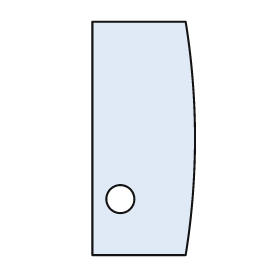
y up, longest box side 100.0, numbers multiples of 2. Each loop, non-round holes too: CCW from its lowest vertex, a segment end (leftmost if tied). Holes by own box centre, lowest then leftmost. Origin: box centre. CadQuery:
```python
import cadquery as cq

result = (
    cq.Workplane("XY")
    .moveTo(-22.0, -50.0)
    .lineTo(18.0, -50.0)
    .threePointArc((22.0, 0.0), (18.0, 50.0))
    .lineTo(-22.0, 50.0)
    .close()
    .moveTo(-10.0, -26.0)
    .circle(6.0)
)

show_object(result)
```